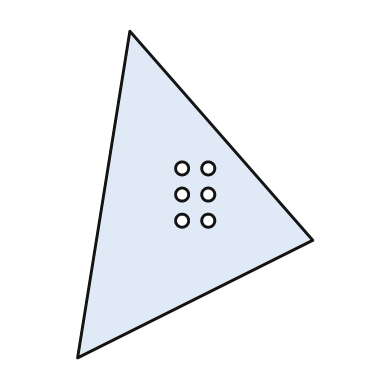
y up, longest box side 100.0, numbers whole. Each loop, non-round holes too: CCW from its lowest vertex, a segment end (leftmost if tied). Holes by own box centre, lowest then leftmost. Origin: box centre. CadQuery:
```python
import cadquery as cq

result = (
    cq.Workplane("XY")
    .moveTo(-36.0, -50.0)
    .lineTo(36.0, -14.0)
    .lineTo(-20.0, 50.0)
    .close()
    .moveTo(-4.0, -8.0)
    .circle(2.0)
    .moveTo(4.0, -8.0)
    .circle(2.0)
    .moveTo(-4.0, 0.0)
    .circle(2.0)
    .moveTo(4.0, 0.0)
    .circle(2.0)
    .moveTo(-4.0, 8.0)
    .circle(2.0)
    .moveTo(4.0, 8.0)
    .circle(2.0)
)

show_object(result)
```